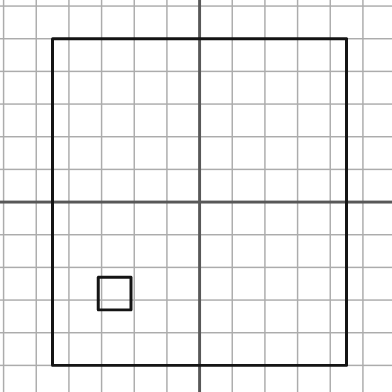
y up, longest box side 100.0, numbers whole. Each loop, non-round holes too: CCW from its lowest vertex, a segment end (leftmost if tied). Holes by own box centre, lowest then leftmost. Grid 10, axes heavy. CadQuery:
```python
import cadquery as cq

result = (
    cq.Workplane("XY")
    .moveTo(-45.0, -50.0)
    .lineTo(45.0, -50.0)
    .lineTo(45.0, 50.0)
    .lineTo(-45.0, 50.0)
    .close()
    .moveTo(-31.0, -33.0)
    .lineTo(-21.0, -33.0)
    .lineTo(-21.0, -23.0)
    .lineTo(-31.0, -23.0)
    .close()
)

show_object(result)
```